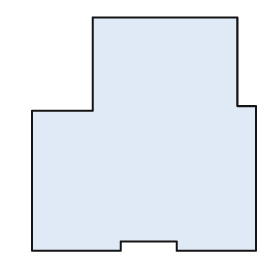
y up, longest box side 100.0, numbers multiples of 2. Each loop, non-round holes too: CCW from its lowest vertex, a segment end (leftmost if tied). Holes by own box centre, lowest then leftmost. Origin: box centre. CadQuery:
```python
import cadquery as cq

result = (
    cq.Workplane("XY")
    .moveTo(-48.0, -50.0)
    .lineTo(-10.0, -50.0)
    .lineTo(-10.0, -46.0)
    .lineTo(14.0, -46.0)
    .lineTo(14.0, -50.0)
    .lineTo(48.0, -50.0)
    .lineTo(48.0, 12.0)
    .lineTo(40.0, 12.0)
    .lineTo(40.0, 50.0)
    .lineTo(-22.0, 50.0)
    .lineTo(-22.0, 10.0)
    .lineTo(-48.0, 10.0)
    .close()
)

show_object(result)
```